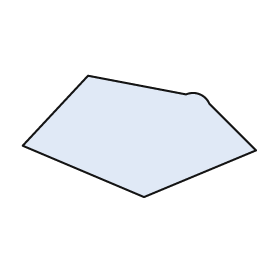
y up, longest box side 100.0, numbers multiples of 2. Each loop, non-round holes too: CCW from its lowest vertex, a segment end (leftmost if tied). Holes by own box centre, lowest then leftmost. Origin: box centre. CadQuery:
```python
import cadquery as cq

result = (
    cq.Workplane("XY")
    .moveTo(2.0, -26.0)
    .lineTo(50.0, -6.0)
    .lineTo(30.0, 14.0)
    .threePointArc((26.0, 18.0), (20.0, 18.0))
    .lineTo(-22.0, 26.0)
    .lineTo(-50.0, -4.0)
    .close()
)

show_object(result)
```